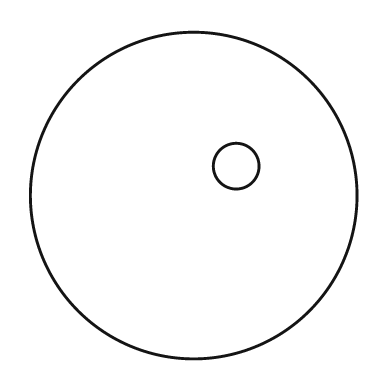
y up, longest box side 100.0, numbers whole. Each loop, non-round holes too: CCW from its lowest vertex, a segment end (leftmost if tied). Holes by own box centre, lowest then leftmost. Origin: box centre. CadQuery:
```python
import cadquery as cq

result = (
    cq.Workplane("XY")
    .moveTo(0.0, 0.0)
    .circle(50.0)
    .moveTo(13.0, 9.0)
    .circle(7.0)
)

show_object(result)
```